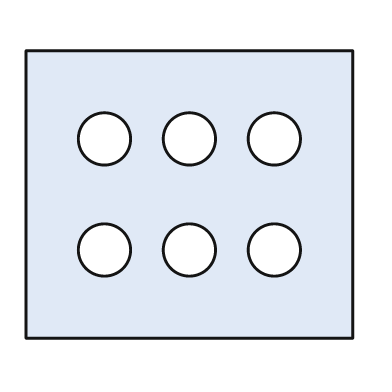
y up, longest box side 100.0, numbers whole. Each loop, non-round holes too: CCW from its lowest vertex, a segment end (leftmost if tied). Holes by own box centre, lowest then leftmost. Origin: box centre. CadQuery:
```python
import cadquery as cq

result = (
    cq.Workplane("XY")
    .moveTo(-50.0, -44.0)
    .lineTo(50.0, -44.0)
    .lineTo(50.0, 44.0)
    .lineTo(-50.0, 44.0)
    .close()
    .moveTo(-26.0, -17.0)
    .circle(8.0)
    .moveTo(0.0, -17.0)
    .circle(8.0)
    .moveTo(26.0, -17.0)
    .circle(8.0)
    .moveTo(-26.0, 17.0)
    .circle(8.0)
    .moveTo(0.0, 17.0)
    .circle(8.0)
    .moveTo(26.0, 17.0)
    .circle(8.0)
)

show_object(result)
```